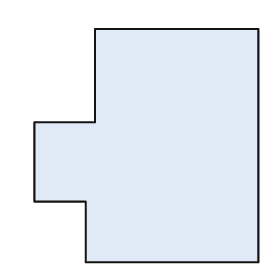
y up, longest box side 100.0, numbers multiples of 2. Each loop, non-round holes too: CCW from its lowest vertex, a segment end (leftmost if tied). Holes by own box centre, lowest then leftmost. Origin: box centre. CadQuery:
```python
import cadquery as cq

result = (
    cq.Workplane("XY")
    .moveTo(-26.0, -50.0)
    .lineTo(48.0, -50.0)
    .lineTo(48.0, 50.0)
    .lineTo(-22.0, 50.0)
    .lineTo(-22.0, 10.0)
    .lineTo(-48.0, 10.0)
    .lineTo(-48.0, -24.0)
    .lineTo(-26.0, -24.0)
    .close()
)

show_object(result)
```